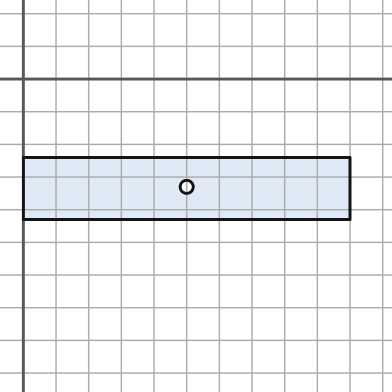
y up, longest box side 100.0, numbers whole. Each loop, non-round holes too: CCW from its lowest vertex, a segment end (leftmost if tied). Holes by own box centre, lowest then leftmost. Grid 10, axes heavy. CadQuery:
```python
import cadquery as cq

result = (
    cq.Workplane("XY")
    .moveTo(0.0, -43.0)
    .lineTo(100.0, -43.0)
    .lineTo(100.0, -24.0)
    .lineTo(0.0, -24.0)
    .close()
    .moveTo(50.0, -33.0)
    .circle(2.0)
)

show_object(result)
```